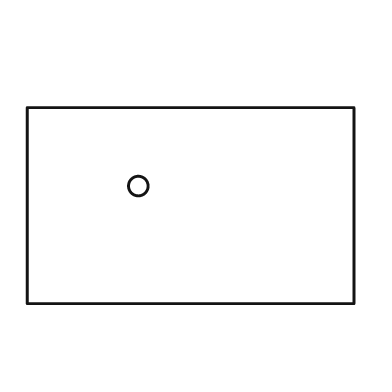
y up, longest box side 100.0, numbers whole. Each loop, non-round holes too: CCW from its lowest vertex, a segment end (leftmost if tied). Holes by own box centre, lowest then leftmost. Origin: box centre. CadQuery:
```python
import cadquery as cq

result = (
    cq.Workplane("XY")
    .moveTo(-50.0, -30.0)
    .lineTo(50.0, -30.0)
    .lineTo(50.0, 30.0)
    .lineTo(-50.0, 30.0)
    .close()
    .moveTo(-16.0, 6.0)
    .circle(3.0)
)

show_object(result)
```